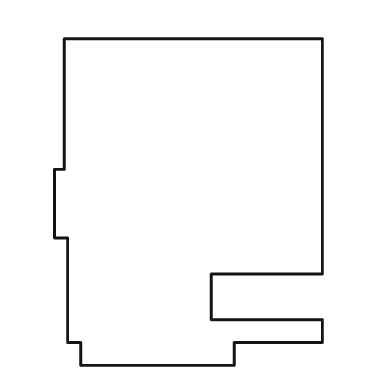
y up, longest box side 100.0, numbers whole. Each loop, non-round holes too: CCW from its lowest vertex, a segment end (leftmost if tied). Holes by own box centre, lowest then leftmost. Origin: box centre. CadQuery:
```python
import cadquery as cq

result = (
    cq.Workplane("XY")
    .moveTo(-33.0, -50.0)
    .lineTo(14.0, -50.0)
    .lineTo(14.0, -43.0)
    .lineTo(41.0, -43.0)
    .lineTo(41.0, -36.0)
    .lineTo(7.0, -36.0)
    .lineTo(7.0, -22.0)
    .lineTo(41.0, -22.0)
    .lineTo(41.0, 50.0)
    .lineTo(-38.0, 50.0)
    .lineTo(-38.0, 10.0)
    .lineTo(-41.0, 10.0)
    .lineTo(-41.0, -11.0)
    .lineTo(-37.0, -11.0)
    .lineTo(-37.0, -43.0)
    .lineTo(-33.0, -43.0)
    .close()
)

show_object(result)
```